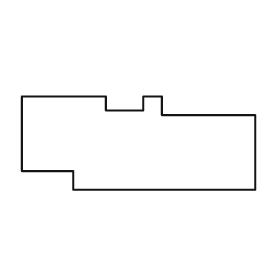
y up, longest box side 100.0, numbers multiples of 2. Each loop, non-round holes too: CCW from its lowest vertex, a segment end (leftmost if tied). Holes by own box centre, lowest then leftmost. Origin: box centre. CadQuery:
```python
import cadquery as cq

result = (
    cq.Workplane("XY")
    .moveTo(-28.0, -20.0)
    .lineTo(50.0, -20.0)
    .lineTo(50.0, 12.0)
    .lineTo(10.0, 12.0)
    .lineTo(10.0, 20.0)
    .lineTo(2.0, 20.0)
    .lineTo(2.0, 14.0)
    .lineTo(-14.0, 14.0)
    .lineTo(-14.0, 20.0)
    .lineTo(-50.0, 20.0)
    .lineTo(-50.0, -12.0)
    .lineTo(-28.0, -12.0)
    .close()
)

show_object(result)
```